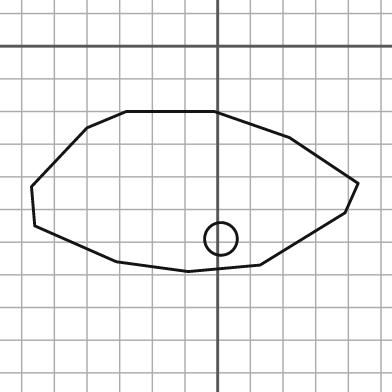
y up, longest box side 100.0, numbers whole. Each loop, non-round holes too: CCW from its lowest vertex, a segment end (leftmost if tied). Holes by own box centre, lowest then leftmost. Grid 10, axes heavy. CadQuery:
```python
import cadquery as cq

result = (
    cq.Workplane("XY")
    .moveTo(-9.0, -69.0)
    .lineTo(13.0, -67.0)
    .lineTo(39.0, -51.0)
    .lineTo(43.0, -42.0)
    .lineTo(22.0, -28.0)
    .lineTo(-1.0, -20.0)
    .lineTo(-28.0, -20.0)
    .lineTo(-40.0, -25.0)
    .lineTo(-57.0, -43.0)
    .lineTo(-56.0, -55.0)
    .lineTo(-31.0, -66.0)
    .close()
    .moveTo(1.0, -59.0)
    .circle(5.0)
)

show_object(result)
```